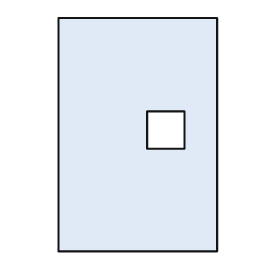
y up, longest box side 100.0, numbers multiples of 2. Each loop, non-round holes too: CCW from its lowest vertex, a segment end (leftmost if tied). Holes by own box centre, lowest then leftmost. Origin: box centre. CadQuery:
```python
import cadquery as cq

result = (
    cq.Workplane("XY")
    .moveTo(-34.0, -50.0)
    .lineTo(34.0, -50.0)
    .lineTo(34.0, 50.0)
    .lineTo(-34.0, 50.0)
    .close()
    .moveTo(4.0, -6.0)
    .lineTo(20.0, -6.0)
    .lineTo(20.0, 10.0)
    .lineTo(4.0, 10.0)
    .close()
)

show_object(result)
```